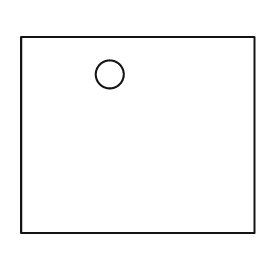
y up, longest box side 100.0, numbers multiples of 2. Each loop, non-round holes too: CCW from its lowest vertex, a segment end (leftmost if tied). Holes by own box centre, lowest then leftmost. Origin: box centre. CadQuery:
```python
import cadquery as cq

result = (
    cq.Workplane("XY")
    .moveTo(-50.0, -42.0)
    .lineTo(50.0, -42.0)
    .lineTo(50.0, 42.0)
    .lineTo(-50.0, 42.0)
    .close()
    .moveTo(-12.0, 26.0)
    .circle(6.0)
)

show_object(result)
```